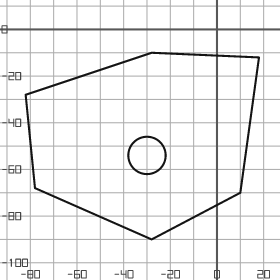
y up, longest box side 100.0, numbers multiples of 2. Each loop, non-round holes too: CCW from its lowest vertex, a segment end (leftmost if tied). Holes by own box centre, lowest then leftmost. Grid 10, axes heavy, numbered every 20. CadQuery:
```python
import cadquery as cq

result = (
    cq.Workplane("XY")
    .moveTo(-28.0, -90.0)
    .lineTo(10.0, -70.0)
    .lineTo(18.0, -12.0)
    .lineTo(-28.0, -10.0)
    .lineTo(-82.0, -28.0)
    .lineTo(-78.0, -68.0)
    .close()
    .moveTo(-30.0, -54.0)
    .circle(8.0)
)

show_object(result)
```